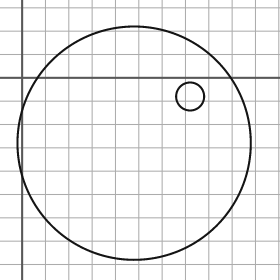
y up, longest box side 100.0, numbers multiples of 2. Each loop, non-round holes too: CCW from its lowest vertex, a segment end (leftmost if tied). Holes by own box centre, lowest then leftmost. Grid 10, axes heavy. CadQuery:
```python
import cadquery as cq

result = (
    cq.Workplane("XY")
    .moveTo(48.0, -28.0)
    .circle(50.0)
    .moveTo(72.0, -8.0)
    .circle(6.0)
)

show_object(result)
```